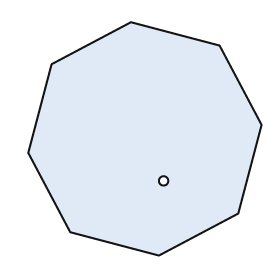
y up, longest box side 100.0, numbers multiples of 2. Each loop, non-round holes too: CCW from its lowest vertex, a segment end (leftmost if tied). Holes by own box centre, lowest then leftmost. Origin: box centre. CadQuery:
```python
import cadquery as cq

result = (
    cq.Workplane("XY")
    .moveTo(6.0, -50.0)
    .lineTo(40.0, -32.0)
    .lineTo(50.0, 6.0)
    .lineTo(32.0, 40.0)
    .lineTo(-6.0, 50.0)
    .lineTo(-40.0, 32.0)
    .lineTo(-50.0, -6.0)
    .lineTo(-32.0, -40.0)
    .close()
    .moveTo(8.0, -18.0)
    .circle(2.0)
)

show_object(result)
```